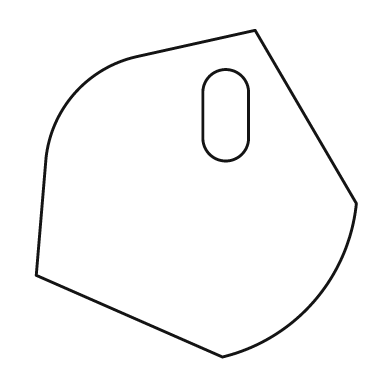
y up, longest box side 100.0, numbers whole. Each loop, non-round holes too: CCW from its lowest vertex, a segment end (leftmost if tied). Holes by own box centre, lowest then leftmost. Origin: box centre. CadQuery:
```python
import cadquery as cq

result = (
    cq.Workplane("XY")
    .moveTo(8.0, -50.0)
    .threePointArc((36.0, -33.0), (49.0, -3.0))
    .lineTo(18.0, 50.0)
    .lineTo(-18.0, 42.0)
    .threePointArc((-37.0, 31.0), (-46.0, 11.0))
    .lineTo(-49.0, -25.0)
    .close()
    .moveTo(2.0, 17.0)
    .threePointArc((9.0, 10.0), (16.0, 17.0))
    .lineTo(16.0, 31.0)
    .threePointArc((9.0, 38.0), (2.0, 31.0))
    .close()
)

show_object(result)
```